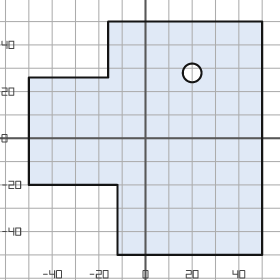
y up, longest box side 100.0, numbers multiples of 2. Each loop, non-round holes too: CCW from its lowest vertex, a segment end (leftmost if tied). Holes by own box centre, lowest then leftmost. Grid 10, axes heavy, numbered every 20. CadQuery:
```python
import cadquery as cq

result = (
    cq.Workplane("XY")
    .moveTo(-12.0, -50.0)
    .lineTo(50.0, -50.0)
    .lineTo(50.0, 50.0)
    .lineTo(-16.0, 50.0)
    .lineTo(-16.0, 26.0)
    .lineTo(-50.0, 26.0)
    .lineTo(-50.0, -20.0)
    .lineTo(-12.0, -20.0)
    .close()
    .moveTo(20.0, 28.0)
    .circle(4.0)
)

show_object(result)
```